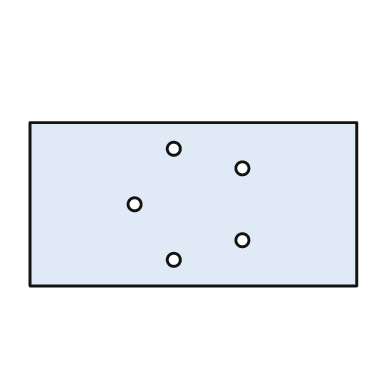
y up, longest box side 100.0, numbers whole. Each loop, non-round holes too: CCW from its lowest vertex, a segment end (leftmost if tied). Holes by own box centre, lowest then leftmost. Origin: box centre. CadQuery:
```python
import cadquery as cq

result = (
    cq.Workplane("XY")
    .moveTo(-50.0, -25.0)
    .lineTo(50.0, -25.0)
    .lineTo(50.0, 25.0)
    .lineTo(-50.0, 25.0)
    .close()
    .moveTo(-6.0, -17.0)
    .circle(2.0)
    .moveTo(15.0, -11.0)
    .circle(2.0)
    .moveTo(-18.0, 0.0)
    .circle(2.0)
    .moveTo(15.0, 11.0)
    .circle(2.0)
    .moveTo(-6.0, 17.0)
    .circle(2.0)
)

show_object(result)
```